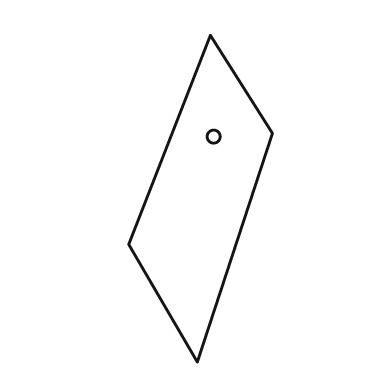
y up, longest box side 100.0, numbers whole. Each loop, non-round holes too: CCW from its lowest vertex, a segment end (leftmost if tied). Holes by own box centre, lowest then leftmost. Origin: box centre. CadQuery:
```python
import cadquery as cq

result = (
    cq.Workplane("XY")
    .moveTo(-1.0, -50.0)
    .lineTo(22.0, 20.0)
    .lineTo(3.0, 50.0)
    .lineTo(-22.0, -14.0)
    .close()
    .moveTo(4.0, 19.0)
    .circle(2.0)
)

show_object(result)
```